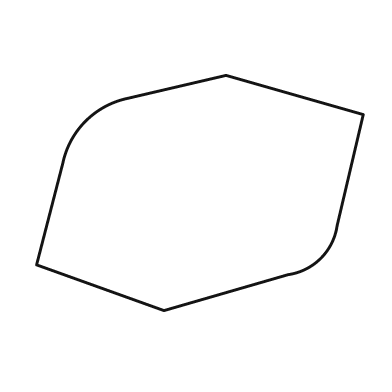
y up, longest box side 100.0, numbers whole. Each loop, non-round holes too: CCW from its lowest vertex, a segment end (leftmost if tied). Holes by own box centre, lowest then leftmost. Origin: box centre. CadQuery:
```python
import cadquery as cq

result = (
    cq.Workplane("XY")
    .moveTo(-11.0, -36.0)
    .lineTo(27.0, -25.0)
    .threePointArc((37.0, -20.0), (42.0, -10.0))
    .lineTo(50.0, 24.0)
    .lineTo(8.0, 36.0)
    .lineTo(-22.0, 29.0)
    .threePointArc((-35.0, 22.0), (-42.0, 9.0))
    .lineTo(-50.0, -22.0)
    .close()
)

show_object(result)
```